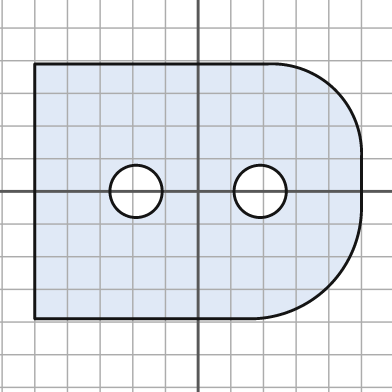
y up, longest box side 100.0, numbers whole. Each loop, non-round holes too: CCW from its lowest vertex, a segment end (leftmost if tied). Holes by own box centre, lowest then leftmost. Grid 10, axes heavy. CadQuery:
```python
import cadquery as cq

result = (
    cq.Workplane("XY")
    .moveTo(-50.0, -39.0)
    .lineTo(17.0, -39.0)
    .threePointArc((40.0, -29.0), (50.0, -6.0))
    .lineTo(50.0, 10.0)
    .threePointArc((42.0, 31.0), (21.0, 39.0))
    .lineTo(-50.0, 39.0)
    .close()
    .moveTo(-19.0, 0.0)
    .circle(8.0)
    .moveTo(19.0, 0.0)
    .circle(8.0)
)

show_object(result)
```